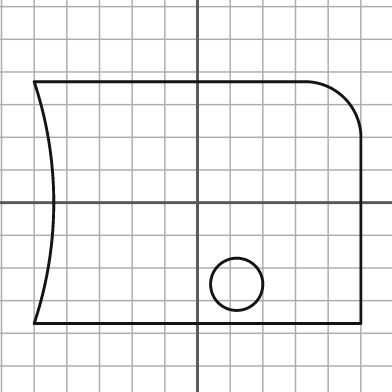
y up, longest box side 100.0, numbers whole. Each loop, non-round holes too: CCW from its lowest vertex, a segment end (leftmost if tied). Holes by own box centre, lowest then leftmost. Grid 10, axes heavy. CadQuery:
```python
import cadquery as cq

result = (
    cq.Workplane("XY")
    .moveTo(-50.0, -37.0)
    .lineTo(50.0, -37.0)
    .lineTo(50.0, 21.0)
    .threePointArc((45.0, 32.0), (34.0, 37.0))
    .lineTo(-50.0, 37.0)
    .threePointArc((-44.0, 0.0), (-50.0, -37.0))
    .close()
    .moveTo(12.0, -25.0)
    .circle(8.0)
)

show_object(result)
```